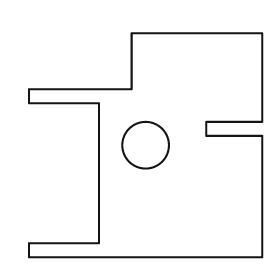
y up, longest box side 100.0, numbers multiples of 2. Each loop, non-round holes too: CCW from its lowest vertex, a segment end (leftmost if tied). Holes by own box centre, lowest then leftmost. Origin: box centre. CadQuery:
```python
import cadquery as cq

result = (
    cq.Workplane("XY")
    .moveTo(-50.0, -48.0)
    .lineTo(50.0, -48.0)
    .lineTo(50.0, 4.0)
    .lineTo(26.0, 4.0)
    .lineTo(26.0, 10.0)
    .lineTo(50.0, 10.0)
    .lineTo(50.0, 48.0)
    .lineTo(-6.0, 48.0)
    .lineTo(-6.0, 24.0)
    .lineTo(-50.0, 24.0)
    .lineTo(-50.0, 18.0)
    .lineTo(-20.0, 18.0)
    .lineTo(-20.0, -42.0)
    .lineTo(-50.0, -42.0)
    .close()
    .moveTo(0.0, 0.0)
    .circle(10.0)
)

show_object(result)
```